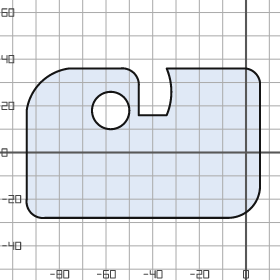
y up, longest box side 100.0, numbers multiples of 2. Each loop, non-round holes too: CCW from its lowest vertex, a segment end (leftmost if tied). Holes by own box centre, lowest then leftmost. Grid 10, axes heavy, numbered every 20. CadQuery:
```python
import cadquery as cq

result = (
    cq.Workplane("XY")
    .moveTo(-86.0, -28.0)
    .lineTo(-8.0, -28.0)
    .threePointArc((2.0, -24.0), (6.0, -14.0))
    .lineTo(6.0, 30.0)
    .threePointArc((4.0, 34.0), (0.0, 36.0))
    .lineTo(-34.0, 36.0)
    .threePointArc((-32.0, 26.0), (-34.0, 16.0))
    .lineTo(-46.0, 16.0)
    .lineTo(-46.0, 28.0)
    .threePointArc((-48.0, 34.0), (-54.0, 36.0))
    .lineTo(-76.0, 36.0)
    .threePointArc((-88.0, 30.0), (-94.0, 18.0))
    .lineTo(-94.0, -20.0)
    .threePointArc((-92.0, -26.0), (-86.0, -28.0))
    .close()
    .moveTo(-58.0, 18.0)
    .circle(8.0)
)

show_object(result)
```